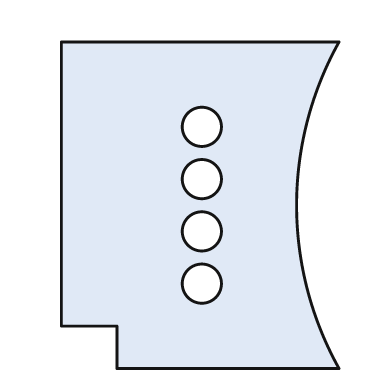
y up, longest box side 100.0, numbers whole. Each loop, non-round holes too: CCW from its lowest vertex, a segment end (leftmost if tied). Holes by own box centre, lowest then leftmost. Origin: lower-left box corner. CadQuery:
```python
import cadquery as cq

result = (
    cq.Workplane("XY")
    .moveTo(17.0, 0.0)
    .lineTo(85.0, 0.0)
    .threePointArc((72.0, 50.0), (85.0, 100.0))
    .lineTo(0.0, 100.0)
    .lineTo(0.0, 13.0)
    .lineTo(17.0, 13.0)
    .close()
    .moveTo(43.0, 26.0)
    .circle(6.0)
    .moveTo(43.0, 42.0)
    .circle(6.0)
    .moveTo(43.0, 58.0)
    .circle(6.0)
    .moveTo(43.0, 74.0)
    .circle(6.0)
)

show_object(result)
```